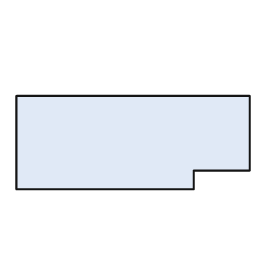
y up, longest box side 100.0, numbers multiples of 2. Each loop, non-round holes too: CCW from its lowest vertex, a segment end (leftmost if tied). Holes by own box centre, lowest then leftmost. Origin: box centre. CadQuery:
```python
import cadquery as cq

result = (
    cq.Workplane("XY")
    .moveTo(-50.0, -20.0)
    .lineTo(26.0, -20.0)
    .lineTo(26.0, -12.0)
    .lineTo(50.0, -12.0)
    .lineTo(50.0, 20.0)
    .lineTo(-50.0, 20.0)
    .close()
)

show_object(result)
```